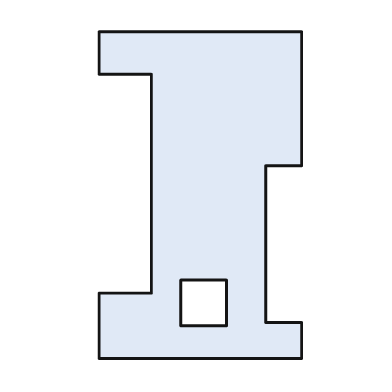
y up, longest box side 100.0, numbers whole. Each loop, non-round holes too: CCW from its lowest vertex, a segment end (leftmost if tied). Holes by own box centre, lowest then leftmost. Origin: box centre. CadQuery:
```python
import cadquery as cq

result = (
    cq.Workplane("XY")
    .moveTo(-31.0, -50.0)
    .lineTo(31.0, -50.0)
    .lineTo(31.0, -39.0)
    .lineTo(20.0, -39.0)
    .lineTo(20.0, 9.0)
    .lineTo(31.0, 9.0)
    .lineTo(31.0, 50.0)
    .lineTo(-31.0, 50.0)
    .lineTo(-31.0, 37.0)
    .lineTo(-15.0, 37.0)
    .lineTo(-15.0, -30.0)
    .lineTo(-31.0, -30.0)
    .close()
    .moveTo(-6.0, -40.0)
    .lineTo(8.0, -40.0)
    .lineTo(8.0, -26.0)
    .lineTo(-6.0, -26.0)
    .close()
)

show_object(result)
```